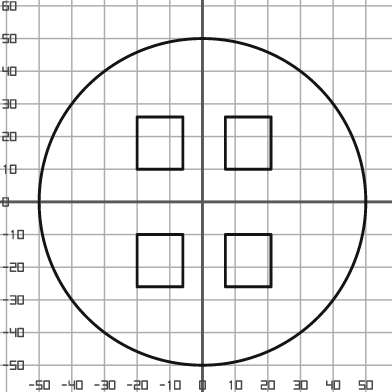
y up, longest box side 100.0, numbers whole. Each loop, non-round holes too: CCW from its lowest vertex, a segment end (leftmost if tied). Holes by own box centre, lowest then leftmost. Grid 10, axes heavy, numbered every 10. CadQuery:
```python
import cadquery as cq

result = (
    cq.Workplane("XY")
    .moveTo(0.0, 0.0)
    .circle(50.0)
    .moveTo(-20.0, -26.0)
    .lineTo(-6.0, -26.0)
    .lineTo(-6.0, -10.0)
    .lineTo(-20.0, -10.0)
    .close()
    .moveTo(7.0, -26.0)
    .lineTo(21.0, -26.0)
    .lineTo(21.0, -10.0)
    .lineTo(7.0, -10.0)
    .close()
    .moveTo(-20.0, 10.0)
    .lineTo(-6.0, 10.0)
    .lineTo(-6.0, 26.0)
    .lineTo(-20.0, 26.0)
    .close()
    .moveTo(7.0, 10.0)
    .lineTo(21.0, 10.0)
    .lineTo(21.0, 26.0)
    .lineTo(7.0, 26.0)
    .close()
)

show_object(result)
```